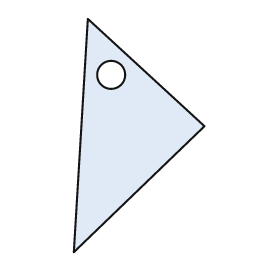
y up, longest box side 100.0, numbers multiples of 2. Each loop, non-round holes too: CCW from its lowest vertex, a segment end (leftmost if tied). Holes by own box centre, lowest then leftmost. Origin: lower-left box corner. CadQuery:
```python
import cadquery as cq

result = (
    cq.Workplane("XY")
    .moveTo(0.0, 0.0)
    .lineTo(56.0, 54.0)
    .lineTo(6.0, 100.0)
    .close()
    .moveTo(16.0, 76.0)
    .circle(6.0)
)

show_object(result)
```